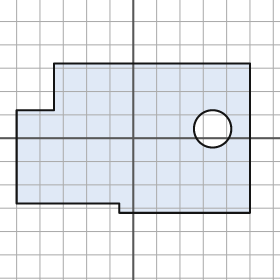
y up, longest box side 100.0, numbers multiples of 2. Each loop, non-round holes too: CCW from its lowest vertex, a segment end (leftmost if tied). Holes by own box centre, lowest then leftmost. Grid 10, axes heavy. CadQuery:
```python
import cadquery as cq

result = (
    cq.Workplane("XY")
    .moveTo(-6.0, -32.0)
    .lineTo(50.0, -32.0)
    .lineTo(50.0, 32.0)
    .lineTo(-34.0, 32.0)
    .lineTo(-34.0, 12.0)
    .lineTo(-50.0, 12.0)
    .lineTo(-50.0, -28.0)
    .lineTo(-6.0, -28.0)
    .close()
    .moveTo(34.0, 4.0)
    .circle(8.0)
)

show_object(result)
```